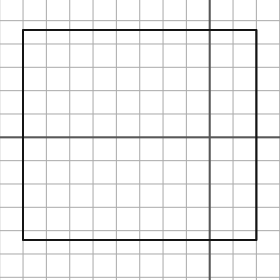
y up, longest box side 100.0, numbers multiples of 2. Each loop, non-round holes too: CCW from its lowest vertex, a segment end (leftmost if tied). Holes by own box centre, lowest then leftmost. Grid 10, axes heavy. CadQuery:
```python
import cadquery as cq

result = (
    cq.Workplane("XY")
    .moveTo(-80.0, -44.0)
    .lineTo(20.0, -44.0)
    .lineTo(20.0, 46.0)
    .lineTo(-80.0, 46.0)
    .close()
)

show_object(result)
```